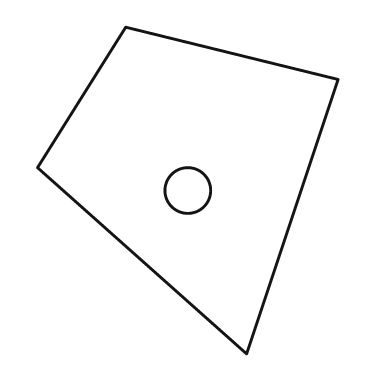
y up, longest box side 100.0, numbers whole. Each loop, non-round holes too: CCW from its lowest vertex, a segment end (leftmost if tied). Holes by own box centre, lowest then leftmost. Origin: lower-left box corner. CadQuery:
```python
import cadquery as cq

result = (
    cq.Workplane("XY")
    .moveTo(64.0, 0.0)
    .lineTo(92.0, 84.0)
    .lineTo(27.0, 100.0)
    .lineTo(0.0, 57.0)
    .close()
    .moveTo(46.0, 50.0)
    .circle(7.0)
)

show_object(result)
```